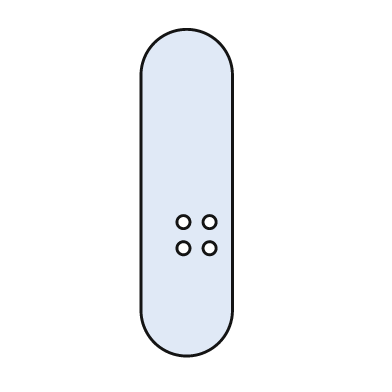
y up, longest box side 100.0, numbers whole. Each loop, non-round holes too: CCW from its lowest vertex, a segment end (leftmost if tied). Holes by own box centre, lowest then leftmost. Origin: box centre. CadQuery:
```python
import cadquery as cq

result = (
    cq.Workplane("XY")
    .moveTo(-14.0, -36.0)
    .threePointArc((0.0, -50.0), (14.0, -36.0))
    .lineTo(14.0, 36.0)
    .threePointArc((0.0, 50.0), (-14.0, 36.0))
    .close()
    .moveTo(-1.0, -17.0)
    .circle(2.0)
    .moveTo(7.0, -17.0)
    .circle(2.0)
    .moveTo(-1.0, -9.0)
    .circle(2.0)
    .moveTo(7.0, -9.0)
    .circle(2.0)
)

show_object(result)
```